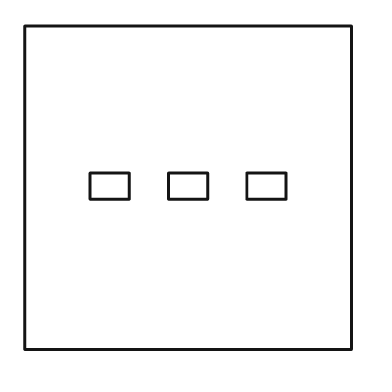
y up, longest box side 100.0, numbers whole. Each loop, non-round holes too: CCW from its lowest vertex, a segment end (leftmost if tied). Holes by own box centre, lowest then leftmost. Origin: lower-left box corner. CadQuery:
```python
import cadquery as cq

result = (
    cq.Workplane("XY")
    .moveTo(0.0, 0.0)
    .lineTo(100.0, 0.0)
    .lineTo(100.0, 99.0)
    .lineTo(0.0, 99.0)
    .close()
    .moveTo(20.0, 46.0)
    .lineTo(32.0, 46.0)
    .lineTo(32.0, 54.0)
    .lineTo(20.0, 54.0)
    .close()
    .moveTo(44.0, 46.0)
    .lineTo(56.0, 46.0)
    .lineTo(56.0, 54.0)
    .lineTo(44.0, 54.0)
    .close()
    .moveTo(68.0, 46.0)
    .lineTo(80.0, 46.0)
    .lineTo(80.0, 54.0)
    .lineTo(68.0, 54.0)
    .close()
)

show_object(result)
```